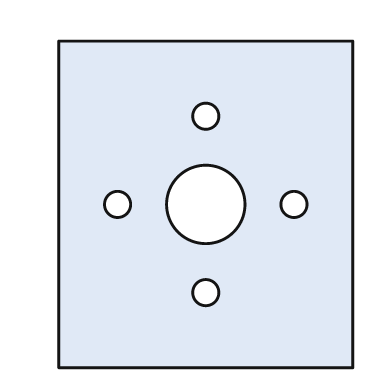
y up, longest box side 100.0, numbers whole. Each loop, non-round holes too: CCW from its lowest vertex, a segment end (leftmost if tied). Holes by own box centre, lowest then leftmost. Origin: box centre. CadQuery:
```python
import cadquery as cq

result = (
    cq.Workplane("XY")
    .moveTo(-45.0, -50.0)
    .lineTo(45.0, -50.0)
    .lineTo(45.0, 50.0)
    .lineTo(-45.0, 50.0)
    .close()
    .moveTo(0.0, -27.0)
    .circle(4.0)
    .moveTo(-27.0, 0.0)
    .circle(4.0)
    .moveTo(0.0, 0.0)
    .circle(12.0)
    .moveTo(27.0, 0.0)
    .circle(4.0)
    .moveTo(0.0, 27.0)
    .circle(4.0)
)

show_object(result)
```